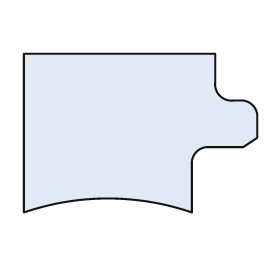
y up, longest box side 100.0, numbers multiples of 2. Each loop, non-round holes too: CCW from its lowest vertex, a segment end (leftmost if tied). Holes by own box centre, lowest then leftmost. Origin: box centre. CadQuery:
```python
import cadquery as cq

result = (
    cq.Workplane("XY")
    .moveTo(-50.0, -34.0)
    .threePointArc((-14.0, -28.0), (22.0, -34.0))
    .lineTo(22.0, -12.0)
    .threePointArc((24.0, -8.0), (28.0, -6.0))
    .lineTo(44.0, -6.0)
    .lineTo(50.0, -2.0)
    .lineTo(50.0, 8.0)
    .threePointArc((48.0, 12.0), (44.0, 14.0))
    .lineTo(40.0, 14.0)
    .threePointArc((34.0, 16.0), (32.0, 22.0))
    .lineTo(32.0, 34.0)
    .lineTo(-50.0, 34.0)
    .close()
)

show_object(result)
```